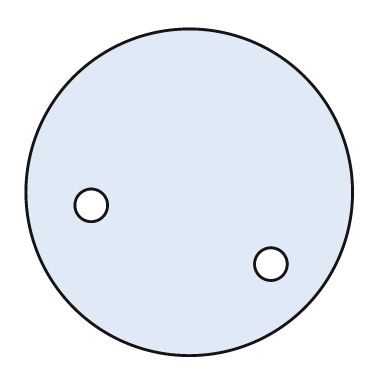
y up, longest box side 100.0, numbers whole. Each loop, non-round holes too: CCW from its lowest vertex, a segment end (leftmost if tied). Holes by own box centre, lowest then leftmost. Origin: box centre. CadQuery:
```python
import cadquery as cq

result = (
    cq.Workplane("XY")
    .moveTo(0.0, 0.0)
    .circle(50.0)
    .moveTo(25.0, -22.0)
    .circle(5.0)
    .moveTo(-30.0, -4.0)
    .circle(5.0)
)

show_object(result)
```